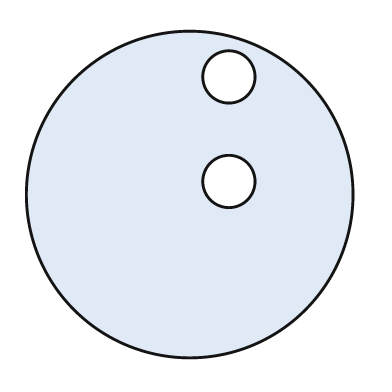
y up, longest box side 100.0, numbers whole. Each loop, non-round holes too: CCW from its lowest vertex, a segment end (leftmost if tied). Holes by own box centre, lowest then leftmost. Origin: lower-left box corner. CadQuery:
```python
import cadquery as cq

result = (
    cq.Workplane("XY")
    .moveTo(50.0, 50.0)
    .circle(50.0)
    .moveTo(62.0, 54.0)
    .circle(8.0)
    .moveTo(62.0, 86.0)
    .circle(8.0)
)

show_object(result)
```